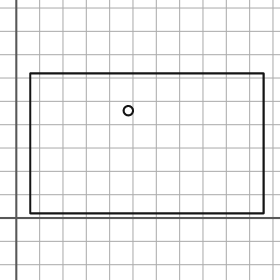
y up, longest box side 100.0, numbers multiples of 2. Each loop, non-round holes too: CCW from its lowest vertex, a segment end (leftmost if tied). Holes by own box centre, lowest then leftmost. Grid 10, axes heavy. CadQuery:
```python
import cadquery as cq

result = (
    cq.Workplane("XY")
    .moveTo(6.0, 2.0)
    .lineTo(106.0, 2.0)
    .lineTo(106.0, 62.0)
    .lineTo(6.0, 62.0)
    .close()
    .moveTo(48.0, 46.0)
    .circle(2.0)
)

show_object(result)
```